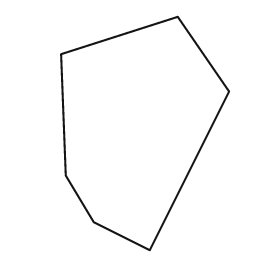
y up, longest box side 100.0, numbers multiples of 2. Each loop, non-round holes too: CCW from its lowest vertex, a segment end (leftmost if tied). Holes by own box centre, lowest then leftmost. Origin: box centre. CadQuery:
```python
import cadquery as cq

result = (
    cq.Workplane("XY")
    .moveTo(2.0, -50.0)
    .lineTo(36.0, 18.0)
    .lineTo(14.0, 50.0)
    .lineTo(-36.0, 34.0)
    .lineTo(-34.0, -18.0)
    .lineTo(-22.0, -38.0)
    .close()
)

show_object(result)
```